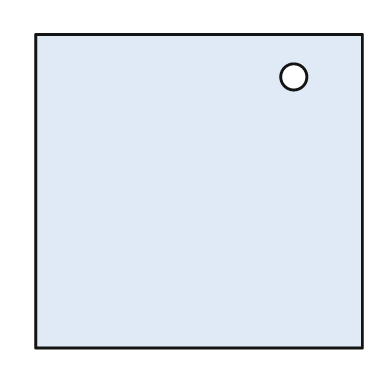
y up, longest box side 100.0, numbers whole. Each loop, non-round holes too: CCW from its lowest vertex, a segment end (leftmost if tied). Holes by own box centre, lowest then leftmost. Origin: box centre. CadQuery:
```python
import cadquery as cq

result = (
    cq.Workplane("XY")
    .moveTo(-50.0, -48.0)
    .lineTo(50.0, -48.0)
    .lineTo(50.0, 48.0)
    .lineTo(-50.0, 48.0)
    .close()
    .moveTo(29.0, 35.0)
    .circle(4.0)
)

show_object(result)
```